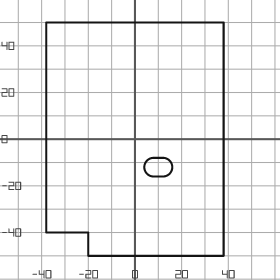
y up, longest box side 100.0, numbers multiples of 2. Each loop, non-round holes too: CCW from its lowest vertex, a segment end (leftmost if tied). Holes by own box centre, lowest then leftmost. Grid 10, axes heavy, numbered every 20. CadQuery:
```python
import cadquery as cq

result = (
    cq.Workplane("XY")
    .moveTo(-20.0, -50.0)
    .lineTo(38.0, -50.0)
    .lineTo(38.0, 50.0)
    .lineTo(-38.0, 50.0)
    .lineTo(-38.0, -40.0)
    .lineTo(-20.0, -40.0)
    .close()
    .moveTo(8.0, -16.0)
    .lineTo(12.0, -16.0)
    .threePointArc((16.0, -12.0), (12.0, -8.0))
    .lineTo(8.0, -8.0)
    .threePointArc((4.0, -12.0), (8.0, -16.0))
    .close()
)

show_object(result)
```